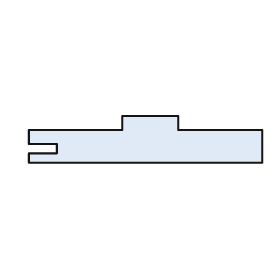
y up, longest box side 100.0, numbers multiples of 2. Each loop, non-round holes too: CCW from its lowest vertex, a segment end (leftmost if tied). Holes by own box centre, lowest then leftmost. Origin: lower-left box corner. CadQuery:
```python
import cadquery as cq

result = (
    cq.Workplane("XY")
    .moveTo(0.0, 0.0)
    .lineTo(100.0, 0.0)
    .lineTo(100.0, 14.0)
    .lineTo(64.0, 14.0)
    .lineTo(64.0, 20.0)
    .lineTo(40.0, 20.0)
    .lineTo(40.0, 14.0)
    .lineTo(0.0, 14.0)
    .lineTo(0.0, 8.0)
    .lineTo(12.0, 8.0)
    .lineTo(12.0, 4.0)
    .lineTo(0.0, 4.0)
    .close()
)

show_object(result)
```